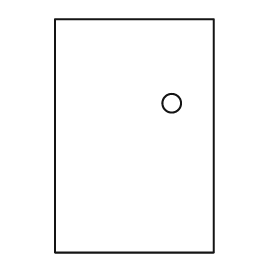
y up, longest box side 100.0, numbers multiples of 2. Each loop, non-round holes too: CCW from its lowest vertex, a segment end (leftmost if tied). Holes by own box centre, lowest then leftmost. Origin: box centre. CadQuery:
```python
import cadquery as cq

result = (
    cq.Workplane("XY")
    .moveTo(-34.0, -50.0)
    .lineTo(34.0, -50.0)
    .lineTo(34.0, 50.0)
    .lineTo(-34.0, 50.0)
    .close()
    .moveTo(16.0, 14.0)
    .circle(4.0)
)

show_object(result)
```